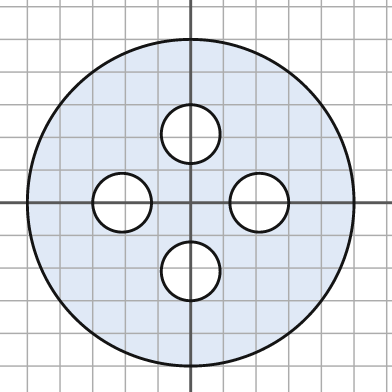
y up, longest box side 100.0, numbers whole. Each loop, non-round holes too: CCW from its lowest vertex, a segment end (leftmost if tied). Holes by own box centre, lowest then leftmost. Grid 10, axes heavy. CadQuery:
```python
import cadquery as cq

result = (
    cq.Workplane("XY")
    .moveTo(0.0, 0.0)
    .circle(50.0)
    .moveTo(0.0, -21.0)
    .circle(9.0)
    .moveTo(-21.0, 0.0)
    .circle(9.0)
    .moveTo(21.0, 0.0)
    .circle(9.0)
    .moveTo(0.0, 21.0)
    .circle(9.0)
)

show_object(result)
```